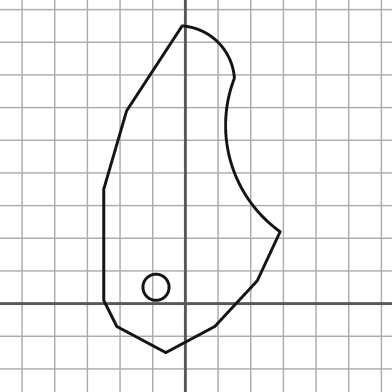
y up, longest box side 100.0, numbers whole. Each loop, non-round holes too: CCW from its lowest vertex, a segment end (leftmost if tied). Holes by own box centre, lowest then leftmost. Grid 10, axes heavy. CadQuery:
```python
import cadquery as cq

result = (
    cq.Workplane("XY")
    .moveTo(-6.0, -15.0)
    .lineTo(9.0, -7.0)
    .lineTo(22.0, 7.0)
    .lineTo(29.0, 22.0)
    .threePointArc((14.0, 43.0), (15.0, 69.0))
    .threePointArc((10.0, 80.0), (-1.0, 85.0))
    .lineTo(-18.0, 59.0)
    .lineTo(-25.0, 35.0)
    .lineTo(-25.0, 1.0)
    .lineTo(-21.0, -7.0)
    .close()
    .moveTo(-9.0, 5.0)
    .circle(4.0)
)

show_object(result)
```